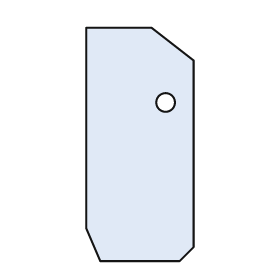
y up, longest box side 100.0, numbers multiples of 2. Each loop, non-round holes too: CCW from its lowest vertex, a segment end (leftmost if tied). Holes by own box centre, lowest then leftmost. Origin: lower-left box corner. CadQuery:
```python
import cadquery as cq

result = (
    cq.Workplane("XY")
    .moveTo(6.0, 0.0)
    .lineTo(40.0, 0.0)
    .lineTo(46.0, 6.0)
    .lineTo(46.0, 86.0)
    .lineTo(28.0, 100.0)
    .lineTo(0.0, 100.0)
    .lineTo(0.0, 14.0)
    .close()
    .moveTo(34.0, 68.0)
    .circle(4.0)
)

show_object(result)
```